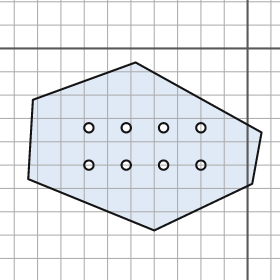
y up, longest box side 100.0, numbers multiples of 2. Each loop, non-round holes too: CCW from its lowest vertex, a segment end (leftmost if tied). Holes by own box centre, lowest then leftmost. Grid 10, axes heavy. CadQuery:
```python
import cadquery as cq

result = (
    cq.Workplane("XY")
    .moveTo(-40.0, -78.0)
    .lineTo(2.0, -58.0)
    .lineTo(6.0, -36.0)
    .lineTo(-48.0, -6.0)
    .lineTo(-92.0, -22.0)
    .lineTo(-94.0, -56.0)
    .close()
    .moveTo(-68.0, -50.0)
    .circle(2.0)
    .moveTo(-52.0, -50.0)
    .circle(2.0)
    .moveTo(-36.0, -50.0)
    .circle(2.0)
    .moveTo(-20.0, -50.0)
    .circle(2.0)
    .moveTo(-68.0, -34.0)
    .circle(2.0)
    .moveTo(-52.0, -34.0)
    .circle(2.0)
    .moveTo(-36.0, -34.0)
    .circle(2.0)
    .moveTo(-20.0, -34.0)
    .circle(2.0)
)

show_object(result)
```